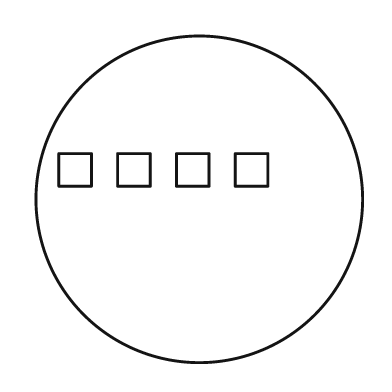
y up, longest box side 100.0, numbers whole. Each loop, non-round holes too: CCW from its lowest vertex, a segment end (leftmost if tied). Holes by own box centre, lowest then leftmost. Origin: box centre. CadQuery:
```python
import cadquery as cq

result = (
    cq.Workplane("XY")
    .moveTo(0.0, 0.0)
    .circle(50.0)
    .moveTo(-43.0, 4.0)
    .lineTo(-33.0, 4.0)
    .lineTo(-33.0, 14.0)
    .lineTo(-43.0, 14.0)
    .close()
    .moveTo(-25.0, 4.0)
    .lineTo(-15.0, 4.0)
    .lineTo(-15.0, 14.0)
    .lineTo(-25.0, 14.0)
    .close()
    .moveTo(-7.0, 4.0)
    .lineTo(3.0, 4.0)
    .lineTo(3.0, 14.0)
    .lineTo(-7.0, 14.0)
    .close()
    .moveTo(11.0, 4.0)
    .lineTo(21.0, 4.0)
    .lineTo(21.0, 14.0)
    .lineTo(11.0, 14.0)
    .close()
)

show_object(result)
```